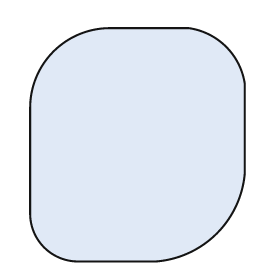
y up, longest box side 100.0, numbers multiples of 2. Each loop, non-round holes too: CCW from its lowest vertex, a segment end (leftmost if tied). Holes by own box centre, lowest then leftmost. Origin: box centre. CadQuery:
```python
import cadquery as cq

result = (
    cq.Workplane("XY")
    .moveTo(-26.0, -50.0)
    .lineTo(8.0, -50.0)
    .threePointArc((34.0, -38.0), (46.0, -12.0))
    .lineTo(46.0, 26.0)
    .threePointArc((38.0, 42.0), (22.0, 50.0))
    .lineTo(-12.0, 50.0)
    .threePointArc((-36.0, 40.0), (-46.0, 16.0))
    .lineTo(-46.0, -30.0)
    .threePointArc((-40.0, -44.0), (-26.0, -50.0))
    .close()
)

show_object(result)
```